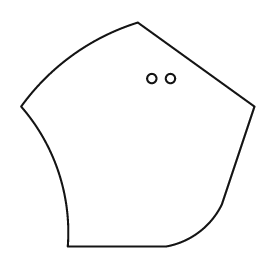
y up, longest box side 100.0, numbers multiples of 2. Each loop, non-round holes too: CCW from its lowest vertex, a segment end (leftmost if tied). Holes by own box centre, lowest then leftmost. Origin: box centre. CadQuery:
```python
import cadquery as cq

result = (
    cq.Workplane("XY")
    .moveTo(-30.0, -48.0)
    .lineTo(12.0, -48.0)
    .threePointArc((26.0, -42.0), (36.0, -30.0))
    .lineTo(50.0, 12.0)
    .lineTo(0.0, 48.0)
    .threePointArc((-28.0, 34.0), (-50.0, 12.0))
    .threePointArc((-34.0, -16.0), (-30.0, -48.0))
    .close()
    .moveTo(6.0, 24.0)
    .circle(2.0)
    .moveTo(14.0, 24.0)
    .circle(2.0)
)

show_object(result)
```